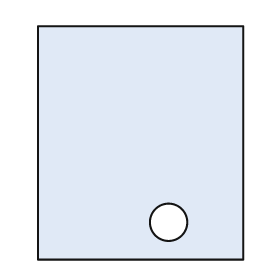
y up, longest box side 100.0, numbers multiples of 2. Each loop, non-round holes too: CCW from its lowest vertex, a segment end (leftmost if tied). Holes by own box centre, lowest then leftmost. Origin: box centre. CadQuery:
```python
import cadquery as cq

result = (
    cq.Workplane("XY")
    .moveTo(-44.0, -50.0)
    .lineTo(44.0, -50.0)
    .lineTo(44.0, 50.0)
    .lineTo(-44.0, 50.0)
    .close()
    .moveTo(12.0, -34.0)
    .circle(8.0)
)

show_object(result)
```